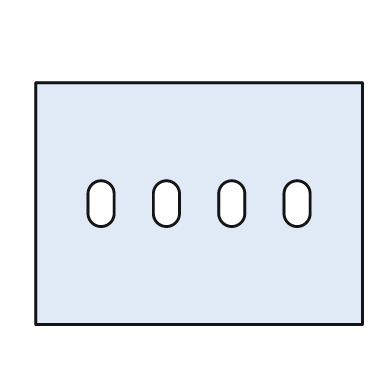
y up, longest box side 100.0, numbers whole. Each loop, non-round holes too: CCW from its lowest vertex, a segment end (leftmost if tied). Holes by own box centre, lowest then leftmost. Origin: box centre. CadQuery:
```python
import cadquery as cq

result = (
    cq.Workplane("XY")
    .moveTo(-50.0, -37.0)
    .lineTo(50.0, -37.0)
    .lineTo(50.0, 37.0)
    .lineTo(-50.0, 37.0)
    .close()
    .moveTo(-34.0, -3.0)
    .threePointArc((-30.0, -7.0), (-26.0, -3.0))
    .lineTo(-26.0, 3.0)
    .threePointArc((-30.0, 7.0), (-34.0, 3.0))
    .close()
    .moveTo(-14.0, -3.0)
    .threePointArc((-10.0, -7.0), (-6.0, -3.0))
    .lineTo(-6.0, 3.0)
    .threePointArc((-10.0, 7.0), (-14.0, 3.0))
    .close()
    .moveTo(6.0, -3.0)
    .threePointArc((10.0, -7.0), (14.0, -3.0))
    .lineTo(14.0, 3.0)
    .threePointArc((10.0, 7.0), (6.0, 3.0))
    .close()
    .moveTo(26.0, -3.0)
    .threePointArc((30.0, -7.0), (34.0, -3.0))
    .lineTo(34.0, 3.0)
    .threePointArc((30.0, 7.0), (26.0, 3.0))
    .close()
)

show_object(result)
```